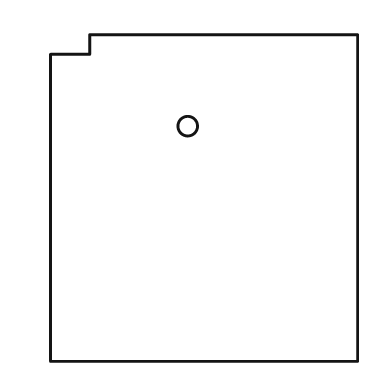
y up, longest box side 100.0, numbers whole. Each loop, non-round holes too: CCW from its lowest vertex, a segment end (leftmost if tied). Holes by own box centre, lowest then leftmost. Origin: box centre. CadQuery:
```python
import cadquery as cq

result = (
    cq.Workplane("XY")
    .moveTo(-47.0, -50.0)
    .lineTo(47.0, -50.0)
    .lineTo(47.0, 50.0)
    .lineTo(-35.0, 50.0)
    .lineTo(-35.0, 44.0)
    .lineTo(-47.0, 44.0)
    .close()
    .moveTo(-5.0, 22.0)
    .circle(3.0)
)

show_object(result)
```